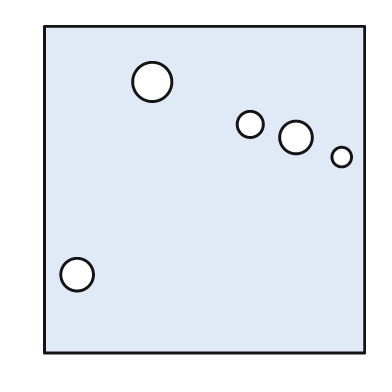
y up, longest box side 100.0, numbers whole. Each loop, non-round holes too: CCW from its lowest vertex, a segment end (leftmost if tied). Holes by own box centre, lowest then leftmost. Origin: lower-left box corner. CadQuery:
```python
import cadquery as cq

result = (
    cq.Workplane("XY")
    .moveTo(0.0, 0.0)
    .lineTo(98.0, 0.0)
    .lineTo(98.0, 100.0)
    .lineTo(0.0, 100.0)
    .close()
    .moveTo(10.0, 24.0)
    .circle(5.0)
    .moveTo(91.0, 60.0)
    .circle(3.0)
    .moveTo(77.0, 66.0)
    .circle(5.0)
    .moveTo(63.0, 70.0)
    .circle(4.0)
    .moveTo(33.0, 83.0)
    .circle(6.0)
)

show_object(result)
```